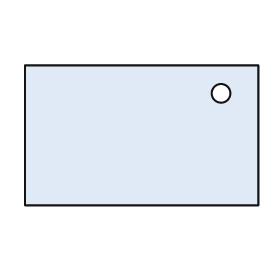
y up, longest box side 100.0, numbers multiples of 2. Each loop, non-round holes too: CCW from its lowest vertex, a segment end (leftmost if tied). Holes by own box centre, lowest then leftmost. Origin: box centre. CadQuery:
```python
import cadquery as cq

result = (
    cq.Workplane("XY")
    .moveTo(-50.0, -30.0)
    .lineTo(50.0, -30.0)
    .lineTo(50.0, 30.0)
    .lineTo(-50.0, 30.0)
    .close()
    .moveTo(34.0, 18.0)
    .circle(4.0)
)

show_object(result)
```